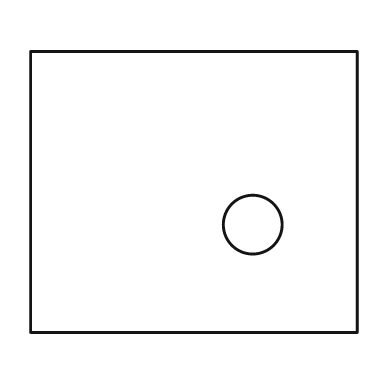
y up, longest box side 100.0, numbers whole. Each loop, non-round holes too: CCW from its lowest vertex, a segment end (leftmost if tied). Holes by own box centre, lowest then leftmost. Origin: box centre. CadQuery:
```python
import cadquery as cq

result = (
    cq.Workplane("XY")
    .moveTo(-50.0, -43.0)
    .lineTo(50.0, -43.0)
    .lineTo(50.0, 43.0)
    .lineTo(-50.0, 43.0)
    .close()
    .moveTo(18.0, -10.0)
    .circle(9.0)
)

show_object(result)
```